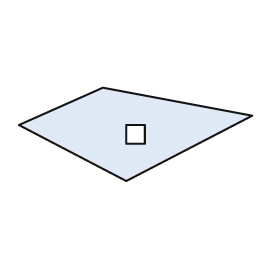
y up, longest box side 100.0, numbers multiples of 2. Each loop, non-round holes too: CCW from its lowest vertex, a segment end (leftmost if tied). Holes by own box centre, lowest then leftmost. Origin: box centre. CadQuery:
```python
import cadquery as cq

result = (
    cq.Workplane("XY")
    .moveTo(-4.0, -20.0)
    .lineTo(50.0, 8.0)
    .lineTo(-14.0, 20.0)
    .lineTo(-50.0, 4.0)
    .close()
    .moveTo(-4.0, -4.0)
    .lineTo(4.0, -4.0)
    .lineTo(4.0, 4.0)
    .lineTo(-4.0, 4.0)
    .close()
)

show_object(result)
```